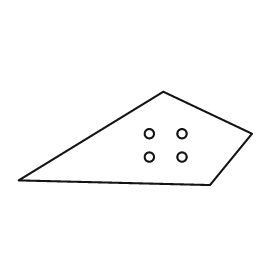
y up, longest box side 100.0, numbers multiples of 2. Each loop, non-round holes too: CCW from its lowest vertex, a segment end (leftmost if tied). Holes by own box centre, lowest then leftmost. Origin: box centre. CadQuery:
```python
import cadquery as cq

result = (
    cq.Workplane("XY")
    .moveTo(32.0, -20.0)
    .lineTo(50.0, 2.0)
    .lineTo(12.0, 20.0)
    .lineTo(-50.0, -18.0)
    .close()
    .moveTo(6.0, -8.0)
    .circle(2.0)
    .moveTo(20.0, -8.0)
    .circle(2.0)
    .moveTo(6.0, 2.0)
    .circle(2.0)
    .moveTo(20.0, 2.0)
    .circle(2.0)
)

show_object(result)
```